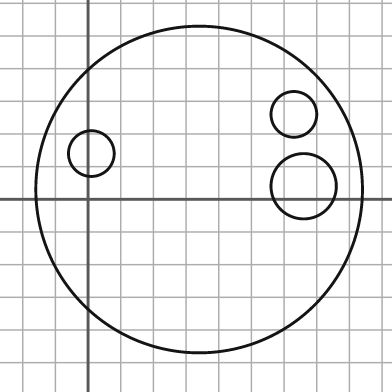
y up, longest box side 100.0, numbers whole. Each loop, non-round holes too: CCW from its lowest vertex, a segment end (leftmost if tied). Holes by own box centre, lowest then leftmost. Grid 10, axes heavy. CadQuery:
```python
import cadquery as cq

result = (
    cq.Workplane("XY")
    .moveTo(34.0, 3.0)
    .circle(50.0)
    .moveTo(66.0, 4.0)
    .circle(10.0)
    .moveTo(1.0, 14.0)
    .circle(7.0)
    .moveTo(63.0, 26.0)
    .circle(7.0)
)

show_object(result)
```